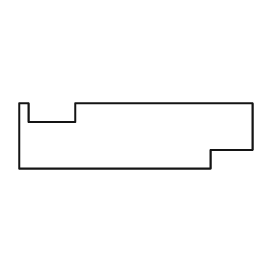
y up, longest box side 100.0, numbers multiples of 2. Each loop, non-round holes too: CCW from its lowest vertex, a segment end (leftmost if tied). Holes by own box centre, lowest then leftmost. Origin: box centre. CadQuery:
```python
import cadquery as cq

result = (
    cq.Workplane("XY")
    .moveTo(-50.0, -14.0)
    .lineTo(32.0, -14.0)
    .lineTo(32.0, -6.0)
    .lineTo(50.0, -6.0)
    .lineTo(50.0, 14.0)
    .lineTo(-26.0, 14.0)
    .lineTo(-26.0, 6.0)
    .lineTo(-46.0, 6.0)
    .lineTo(-46.0, 14.0)
    .lineTo(-50.0, 14.0)
    .close()
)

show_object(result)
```